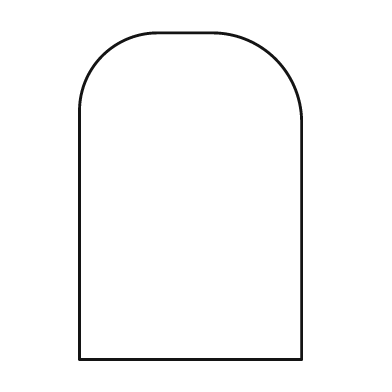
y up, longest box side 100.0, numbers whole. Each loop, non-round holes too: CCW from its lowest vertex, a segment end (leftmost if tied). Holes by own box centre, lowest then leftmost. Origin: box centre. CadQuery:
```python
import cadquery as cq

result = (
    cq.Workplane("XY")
    .moveTo(-34.0, -50.0)
    .lineTo(34.0, -50.0)
    .lineTo(34.0, 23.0)
    .threePointArc((26.0, 42.0), (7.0, 50.0))
    .lineTo(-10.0, 50.0)
    .threePointArc((-27.0, 43.0), (-34.0, 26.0))
    .close()
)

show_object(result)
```